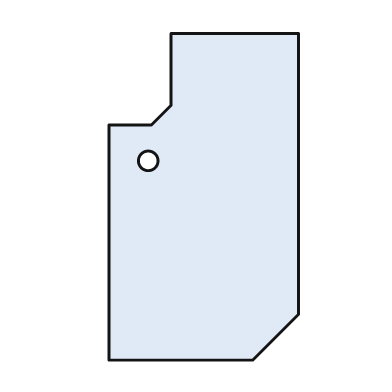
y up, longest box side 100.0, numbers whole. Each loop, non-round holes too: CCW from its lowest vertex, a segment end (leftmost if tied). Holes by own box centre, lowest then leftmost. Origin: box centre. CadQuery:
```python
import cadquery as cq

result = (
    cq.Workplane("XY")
    .moveTo(-29.0, -50.0)
    .lineTo(15.0, -50.0)
    .lineTo(29.0, -36.0)
    .lineTo(29.0, 50.0)
    .lineTo(-10.0, 50.0)
    .lineTo(-10.0, 28.0)
    .lineTo(-16.0, 22.0)
    .lineTo(-29.0, 22.0)
    .close()
    .moveTo(-17.0, 11.0)
    .circle(3.0)
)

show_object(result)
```